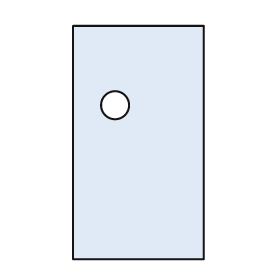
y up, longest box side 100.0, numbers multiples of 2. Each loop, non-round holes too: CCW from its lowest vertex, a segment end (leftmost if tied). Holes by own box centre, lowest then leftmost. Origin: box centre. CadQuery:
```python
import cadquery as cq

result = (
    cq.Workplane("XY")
    .moveTo(-28.0, -50.0)
    .lineTo(28.0, -50.0)
    .lineTo(28.0, 50.0)
    .lineTo(-28.0, 50.0)
    .close()
    .moveTo(-10.0, 16.0)
    .circle(6.0)
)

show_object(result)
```